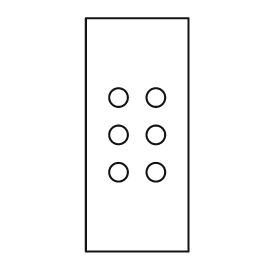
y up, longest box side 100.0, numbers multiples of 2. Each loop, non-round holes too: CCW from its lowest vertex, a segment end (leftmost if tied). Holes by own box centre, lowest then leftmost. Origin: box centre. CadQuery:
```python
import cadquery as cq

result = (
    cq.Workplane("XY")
    .moveTo(-22.0, -50.0)
    .lineTo(22.0, -50.0)
    .lineTo(22.0, 50.0)
    .lineTo(-22.0, 50.0)
    .close()
    .moveTo(-8.0, -16.0)
    .circle(4.0)
    .moveTo(8.0, -16.0)
    .circle(4.0)
    .moveTo(-8.0, 0.0)
    .circle(4.0)
    .moveTo(8.0, 0.0)
    .circle(4.0)
    .moveTo(-8.0, 16.0)
    .circle(4.0)
    .moveTo(8.0, 16.0)
    .circle(4.0)
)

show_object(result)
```